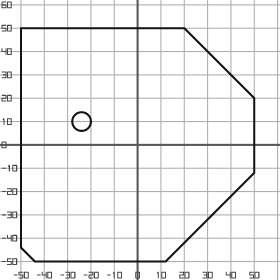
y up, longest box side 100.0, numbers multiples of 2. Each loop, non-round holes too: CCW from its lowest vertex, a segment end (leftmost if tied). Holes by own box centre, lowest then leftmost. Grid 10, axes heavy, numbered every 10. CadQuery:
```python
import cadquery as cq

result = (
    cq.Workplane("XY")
    .moveTo(-44.0, -50.0)
    .lineTo(12.0, -50.0)
    .lineTo(50.0, -12.0)
    .lineTo(50.0, 20.0)
    .lineTo(20.0, 50.0)
    .lineTo(-50.0, 50.0)
    .lineTo(-50.0, -44.0)
    .close()
    .moveTo(-24.0, 10.0)
    .circle(4.0)
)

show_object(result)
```